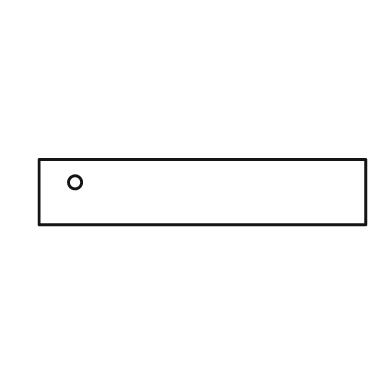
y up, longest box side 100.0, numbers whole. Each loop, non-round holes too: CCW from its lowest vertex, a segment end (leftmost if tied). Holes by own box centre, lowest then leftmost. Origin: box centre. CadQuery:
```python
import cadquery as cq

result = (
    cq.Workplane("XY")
    .moveTo(-50.0, -10.0)
    .lineTo(50.0, -10.0)
    .lineTo(50.0, 10.0)
    .lineTo(-50.0, 10.0)
    .close()
    .moveTo(-39.0, 3.0)
    .circle(2.0)
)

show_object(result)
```